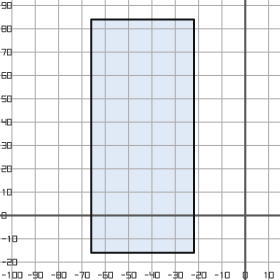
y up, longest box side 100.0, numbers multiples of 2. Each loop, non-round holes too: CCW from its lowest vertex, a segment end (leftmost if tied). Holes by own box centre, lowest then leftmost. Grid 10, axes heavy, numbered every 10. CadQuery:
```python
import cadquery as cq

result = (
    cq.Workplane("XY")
    .moveTo(-66.0, -16.0)
    .lineTo(-22.0, -16.0)
    .lineTo(-22.0, 84.0)
    .lineTo(-66.0, 84.0)
    .close()
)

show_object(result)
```